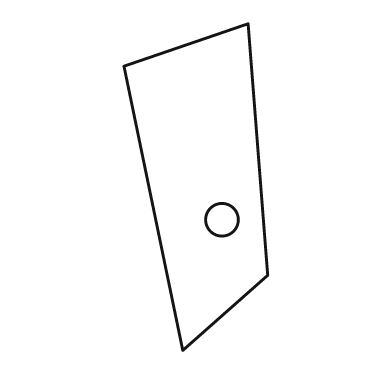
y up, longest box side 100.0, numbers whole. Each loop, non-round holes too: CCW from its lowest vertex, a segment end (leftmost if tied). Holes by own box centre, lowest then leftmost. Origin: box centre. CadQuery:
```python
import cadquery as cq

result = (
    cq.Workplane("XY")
    .moveTo(-4.0, -50.0)
    .lineTo(22.0, -27.0)
    .lineTo(16.0, 50.0)
    .lineTo(-22.0, 37.0)
    .close()
    .moveTo(8.0, -10.0)
    .circle(5.0)
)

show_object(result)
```